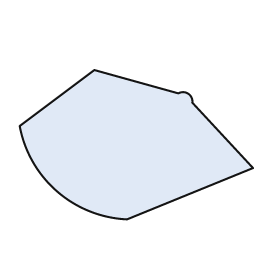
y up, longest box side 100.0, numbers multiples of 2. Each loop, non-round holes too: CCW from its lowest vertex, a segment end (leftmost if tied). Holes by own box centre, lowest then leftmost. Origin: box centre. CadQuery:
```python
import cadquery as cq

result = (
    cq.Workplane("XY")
    .moveTo(-4.0, -32.0)
    .lineTo(50.0, -10.0)
    .lineTo(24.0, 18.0)
    .threePointArc((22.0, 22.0), (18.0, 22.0))
    .lineTo(-18.0, 32.0)
    .lineTo(-50.0, 8.0)
    .threePointArc((-34.0, -20.0), (-4.0, -32.0))
    .close()
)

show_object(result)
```